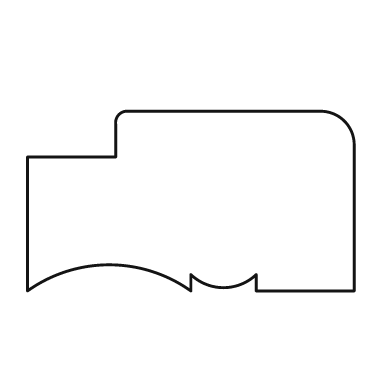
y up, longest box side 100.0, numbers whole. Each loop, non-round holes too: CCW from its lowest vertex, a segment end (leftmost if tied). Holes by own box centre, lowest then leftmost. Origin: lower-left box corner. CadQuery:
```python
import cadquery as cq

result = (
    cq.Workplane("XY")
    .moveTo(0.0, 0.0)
    .threePointArc((25.0, 8.0), (50.0, 0.0))
    .lineTo(50.0, 5.0)
    .threePointArc((60.0, 1.0), (70.0, 5.0))
    .lineTo(70.0, 0.0)
    .lineTo(100.0, 0.0)
    .lineTo(100.0, 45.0)
    .threePointArc((97.0, 52.0), (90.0, 55.0))
    .lineTo(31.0, 55.0)
    .threePointArc((28.0, 54.0), (27.0, 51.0))
    .lineTo(27.0, 41.0)
    .lineTo(0.0, 41.0)
    .close()
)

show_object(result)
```